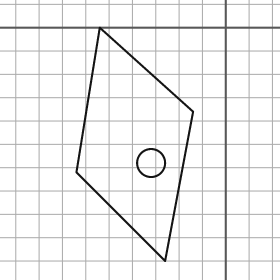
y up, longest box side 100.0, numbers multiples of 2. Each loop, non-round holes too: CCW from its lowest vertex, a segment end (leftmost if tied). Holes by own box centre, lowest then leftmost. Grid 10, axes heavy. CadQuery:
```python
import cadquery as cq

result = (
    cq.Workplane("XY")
    .moveTo(-26.0, -100.0)
    .lineTo(-14.0, -36.0)
    .lineTo(-54.0, 0.0)
    .lineTo(-64.0, -62.0)
    .close()
    .moveTo(-32.0, -58.0)
    .circle(6.0)
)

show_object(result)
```